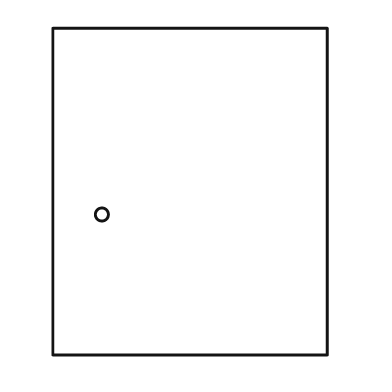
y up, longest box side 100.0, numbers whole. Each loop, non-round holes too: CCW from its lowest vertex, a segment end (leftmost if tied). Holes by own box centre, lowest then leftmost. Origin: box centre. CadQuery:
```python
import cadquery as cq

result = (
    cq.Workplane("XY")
    .moveTo(-42.0, -50.0)
    .lineTo(42.0, -50.0)
    .lineTo(42.0, 50.0)
    .lineTo(-42.0, 50.0)
    .close()
    .moveTo(-27.0, -7.0)
    .circle(2.0)
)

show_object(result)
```